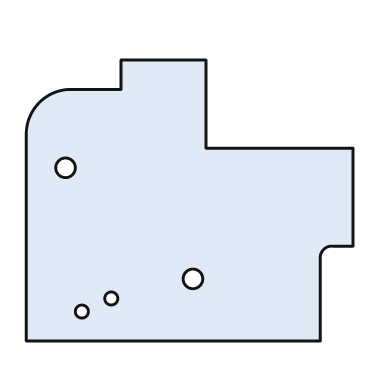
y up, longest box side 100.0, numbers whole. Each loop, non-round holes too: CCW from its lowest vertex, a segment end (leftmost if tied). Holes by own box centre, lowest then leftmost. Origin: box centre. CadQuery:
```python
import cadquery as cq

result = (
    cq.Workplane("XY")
    .moveTo(-50.0, -43.0)
    .lineTo(40.0, -43.0)
    .lineTo(40.0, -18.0)
    .threePointArc((41.0, -15.0), (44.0, -14.0))
    .lineTo(50.0, -14.0)
    .lineTo(50.0, 16.0)
    .lineTo(5.0, 16.0)
    .lineTo(5.0, 43.0)
    .lineTo(-21.0, 43.0)
    .lineTo(-21.0, 34.0)
    .lineTo(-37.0, 34.0)
    .threePointArc((-46.0, 30.0), (-50.0, 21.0))
    .close()
    .moveTo(-33.0, -34.0)
    .circle(2.0)
    .moveTo(-24.0, -30.0)
    .circle(2.0)
    .moveTo(1.0, -24.0)
    .circle(3.0)
    .moveTo(-38.0, 10.0)
    .circle(3.0)
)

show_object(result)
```